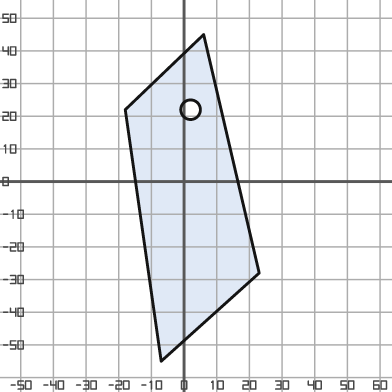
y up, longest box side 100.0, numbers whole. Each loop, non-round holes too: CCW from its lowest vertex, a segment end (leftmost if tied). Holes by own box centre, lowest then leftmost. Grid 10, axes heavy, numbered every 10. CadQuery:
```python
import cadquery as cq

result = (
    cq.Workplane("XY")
    .moveTo(-7.0, -55.0)
    .lineTo(23.0, -28.0)
    .lineTo(6.0, 45.0)
    .lineTo(-18.0, 22.0)
    .close()
    .moveTo(2.0, 22.0)
    .circle(3.0)
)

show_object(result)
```